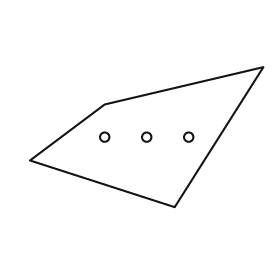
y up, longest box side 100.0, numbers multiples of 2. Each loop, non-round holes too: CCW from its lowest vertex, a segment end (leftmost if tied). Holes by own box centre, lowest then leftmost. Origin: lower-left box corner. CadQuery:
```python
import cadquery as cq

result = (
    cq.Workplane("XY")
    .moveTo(62.0, 0.0)
    .lineTo(100.0, 60.0)
    .lineTo(32.0, 44.0)
    .lineTo(0.0, 20.0)
    .close()
    .moveTo(32.0, 30.0)
    .circle(2.0)
    .moveTo(50.0, 30.0)
    .circle(2.0)
    .moveTo(68.0, 30.0)
    .circle(2.0)
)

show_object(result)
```